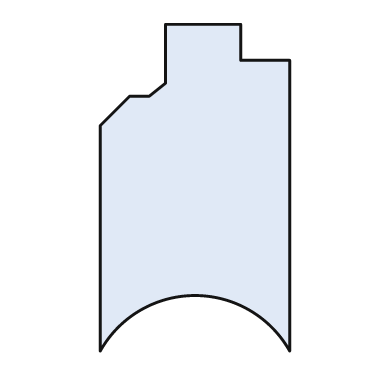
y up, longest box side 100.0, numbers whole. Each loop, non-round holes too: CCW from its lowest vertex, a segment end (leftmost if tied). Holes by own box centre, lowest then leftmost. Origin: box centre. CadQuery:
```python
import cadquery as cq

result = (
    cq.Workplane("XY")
    .moveTo(-29.0, -50.0)
    .threePointArc((0.0, -33.0), (29.0, -50.0))
    .lineTo(29.0, 39.0)
    .lineTo(14.0, 39.0)
    .lineTo(14.0, 50.0)
    .lineTo(-9.0, 50.0)
    .lineTo(-9.0, 32.0)
    .lineTo(-14.0, 28.0)
    .lineTo(-20.0, 28.0)
    .lineTo(-29.0, 19.0)
    .close()
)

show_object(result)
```